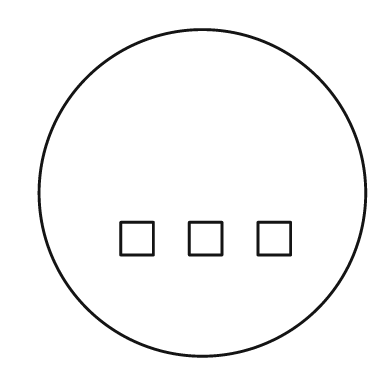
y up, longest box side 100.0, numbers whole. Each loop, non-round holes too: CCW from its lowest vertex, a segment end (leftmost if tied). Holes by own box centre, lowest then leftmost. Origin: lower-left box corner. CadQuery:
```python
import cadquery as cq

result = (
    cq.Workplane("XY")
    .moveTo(50.0, 50.0)
    .circle(50.0)
    .moveTo(25.0, 31.0)
    .lineTo(35.0, 31.0)
    .lineTo(35.0, 41.0)
    .lineTo(25.0, 41.0)
    .close()
    .moveTo(46.0, 31.0)
    .lineTo(56.0, 31.0)
    .lineTo(56.0, 41.0)
    .lineTo(46.0, 41.0)
    .close()
    .moveTo(67.0, 31.0)
    .lineTo(77.0, 31.0)
    .lineTo(77.0, 41.0)
    .lineTo(67.0, 41.0)
    .close()
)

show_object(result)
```